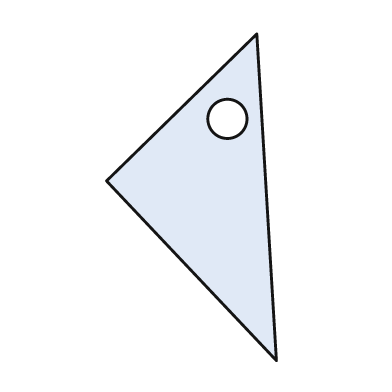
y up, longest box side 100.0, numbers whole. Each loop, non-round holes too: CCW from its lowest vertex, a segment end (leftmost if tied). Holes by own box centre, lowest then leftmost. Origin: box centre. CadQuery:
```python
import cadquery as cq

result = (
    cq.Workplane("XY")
    .moveTo(26.0, -50.0)
    .lineTo(20.0, 50.0)
    .lineTo(-26.0, 5.0)
    .close()
    .moveTo(11.0, 24.0)
    .circle(6.0)
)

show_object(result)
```